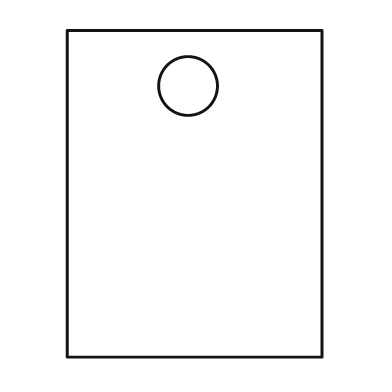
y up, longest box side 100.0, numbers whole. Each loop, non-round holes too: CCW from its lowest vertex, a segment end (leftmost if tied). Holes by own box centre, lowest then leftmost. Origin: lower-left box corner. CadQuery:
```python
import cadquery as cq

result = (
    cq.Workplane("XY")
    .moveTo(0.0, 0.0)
    .lineTo(78.0, 0.0)
    .lineTo(78.0, 100.0)
    .lineTo(0.0, 100.0)
    .close()
    .moveTo(37.0, 83.0)
    .circle(9.0)
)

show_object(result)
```